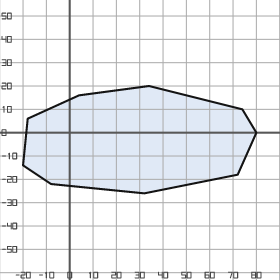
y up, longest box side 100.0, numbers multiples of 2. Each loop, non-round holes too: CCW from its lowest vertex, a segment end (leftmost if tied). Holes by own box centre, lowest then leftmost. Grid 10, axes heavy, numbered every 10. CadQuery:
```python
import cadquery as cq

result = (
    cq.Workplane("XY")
    .moveTo(32.0, -26.0)
    .lineTo(72.0, -18.0)
    .lineTo(80.0, 0.0)
    .lineTo(74.0, 10.0)
    .lineTo(34.0, 20.0)
    .lineTo(4.0, 16.0)
    .lineTo(-18.0, 6.0)
    .lineTo(-20.0, -14.0)
    .lineTo(-8.0, -22.0)
    .close()
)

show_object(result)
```